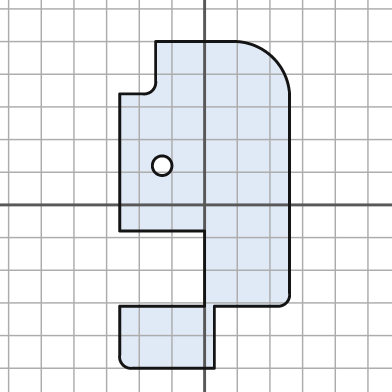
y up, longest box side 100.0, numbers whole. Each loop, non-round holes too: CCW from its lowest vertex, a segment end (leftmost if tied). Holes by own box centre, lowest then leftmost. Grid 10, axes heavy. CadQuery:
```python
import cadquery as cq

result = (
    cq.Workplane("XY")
    .moveTo(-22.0, -50.0)
    .lineTo(3.0, -50.0)
    .lineTo(3.0, -31.0)
    .lineTo(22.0, -31.0)
    .threePointArc((25.0, -30.0), (26.0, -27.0))
    .lineTo(26.0, 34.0)
    .threePointArc((21.0, 45.0), (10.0, 50.0))
    .lineTo(-15.0, 50.0)
    .lineTo(-15.0, 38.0)
    .threePointArc((-16.0, 35.0), (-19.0, 34.0))
    .lineTo(-26.0, 34.0)
    .lineTo(-26.0, -8.0)
    .lineTo(0.0, -8.0)
    .lineTo(0.0, -31.0)
    .lineTo(-26.0, -31.0)
    .lineTo(-26.0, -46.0)
    .threePointArc((-25.0, -49.0), (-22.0, -50.0))
    .close()
    .moveTo(-13.0, 12.0)
    .circle(3.0)
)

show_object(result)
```